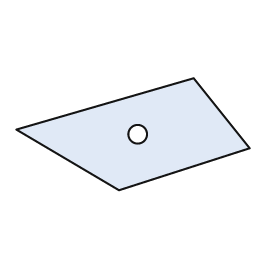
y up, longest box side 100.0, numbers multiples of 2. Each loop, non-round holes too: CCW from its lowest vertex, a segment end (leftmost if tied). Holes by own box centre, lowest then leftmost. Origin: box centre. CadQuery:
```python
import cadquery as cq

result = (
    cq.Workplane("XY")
    .moveTo(-6.0, -24.0)
    .lineTo(50.0, -6.0)
    .lineTo(26.0, 24.0)
    .lineTo(-50.0, 2.0)
    .close()
    .moveTo(2.0, 0.0)
    .circle(4.0)
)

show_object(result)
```